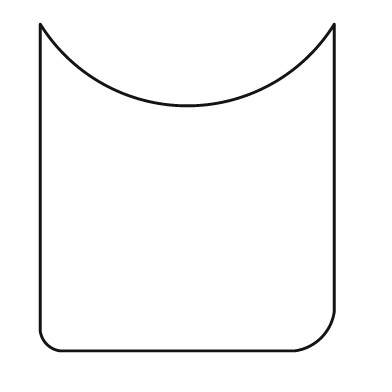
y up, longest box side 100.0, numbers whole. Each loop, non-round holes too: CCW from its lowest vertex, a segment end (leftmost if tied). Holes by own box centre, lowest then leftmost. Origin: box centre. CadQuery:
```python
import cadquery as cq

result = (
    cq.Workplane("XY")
    .moveTo(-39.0, -50.0)
    .lineTo(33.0, -50.0)
    .threePointArc((41.0, -46.0), (45.0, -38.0))
    .lineTo(45.0, 50.0)
    .threePointArc((0.0, 25.0), (-45.0, 50.0))
    .lineTo(-45.0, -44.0)
    .threePointArc((-43.0, -48.0), (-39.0, -50.0))
    .close()
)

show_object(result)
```